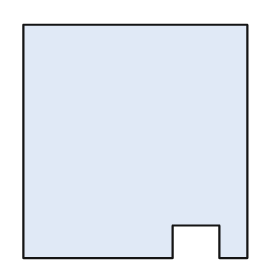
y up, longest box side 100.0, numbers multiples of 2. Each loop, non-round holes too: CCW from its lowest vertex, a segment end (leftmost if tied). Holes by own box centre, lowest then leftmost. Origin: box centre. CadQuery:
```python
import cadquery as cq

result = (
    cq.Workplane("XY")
    .moveTo(-48.0, -50.0)
    .lineTo(16.0, -50.0)
    .lineTo(16.0, -36.0)
    .lineTo(36.0, -36.0)
    .lineTo(36.0, -50.0)
    .lineTo(48.0, -50.0)
    .lineTo(48.0, 50.0)
    .lineTo(-48.0, 50.0)
    .close()
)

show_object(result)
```